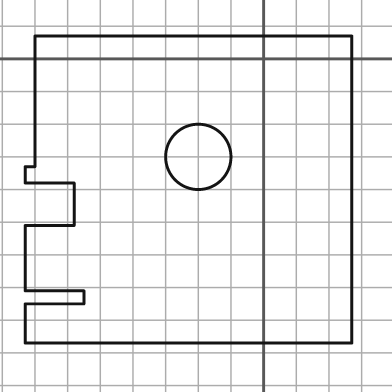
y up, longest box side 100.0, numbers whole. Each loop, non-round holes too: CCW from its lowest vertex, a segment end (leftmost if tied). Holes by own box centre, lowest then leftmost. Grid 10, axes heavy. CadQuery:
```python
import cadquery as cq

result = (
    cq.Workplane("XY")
    .moveTo(-73.0, -87.0)
    .lineTo(27.0, -87.0)
    .lineTo(27.0, 7.0)
    .lineTo(-70.0, 7.0)
    .lineTo(-70.0, -33.0)
    .lineTo(-73.0, -33.0)
    .lineTo(-73.0, -38.0)
    .lineTo(-58.0, -38.0)
    .lineTo(-58.0, -51.0)
    .lineTo(-73.0, -51.0)
    .lineTo(-73.0, -71.0)
    .lineTo(-55.0, -71.0)
    .lineTo(-55.0, -75.0)
    .lineTo(-73.0, -75.0)
    .close()
    .moveTo(-20.0, -30.0)
    .circle(10.0)
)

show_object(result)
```